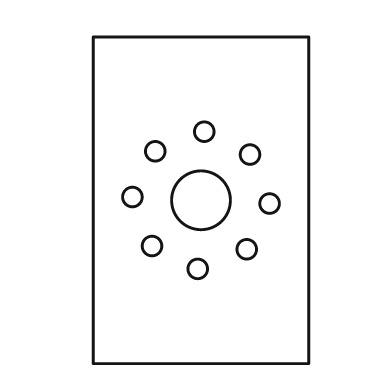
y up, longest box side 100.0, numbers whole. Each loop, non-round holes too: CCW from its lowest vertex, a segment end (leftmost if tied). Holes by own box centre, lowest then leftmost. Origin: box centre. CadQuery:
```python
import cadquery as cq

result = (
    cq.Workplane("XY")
    .moveTo(-33.0, -50.0)
    .lineTo(33.0, -50.0)
    .lineTo(33.0, 50.0)
    .lineTo(-33.0, 50.0)
    .close()
    .moveTo(-1.0, -21.0)
    .circle(3.0)
    .moveTo(14.0, -15.0)
    .circle(3.0)
    .moveTo(-15.0, -14.0)
    .circle(3.0)
    .moveTo(21.0, -1.0)
    .circle(3.0)
    .moveTo(0.0, 0.0)
    .circle(9.0)
    .moveTo(-21.0, 1.0)
    .circle(3.0)
    .moveTo(15.0, 14.0)
    .circle(3.0)
    .moveTo(-14.0, 15.0)
    .circle(3.0)
    .moveTo(1.0, 21.0)
    .circle(3.0)
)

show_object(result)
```